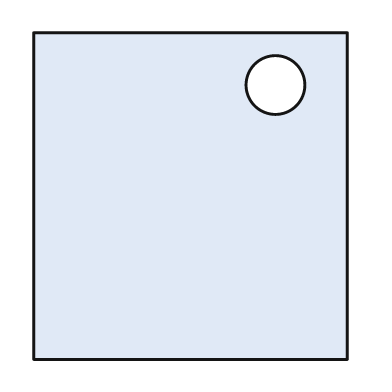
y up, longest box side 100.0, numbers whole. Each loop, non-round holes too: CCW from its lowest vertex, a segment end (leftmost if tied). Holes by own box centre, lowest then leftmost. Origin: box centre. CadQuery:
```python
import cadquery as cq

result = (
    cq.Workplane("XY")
    .moveTo(-48.0, -50.0)
    .lineTo(48.0, -50.0)
    .lineTo(48.0, 50.0)
    .lineTo(-48.0, 50.0)
    .close()
    .moveTo(26.0, 34.0)
    .circle(9.0)
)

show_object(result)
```